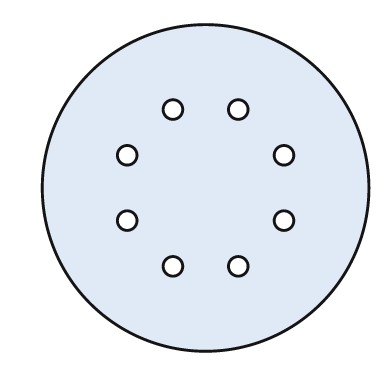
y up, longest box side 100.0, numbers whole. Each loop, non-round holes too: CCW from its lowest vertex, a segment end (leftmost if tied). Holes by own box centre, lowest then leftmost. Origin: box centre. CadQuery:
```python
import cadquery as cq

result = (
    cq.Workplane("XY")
    .moveTo(0.0, 0.0)
    .circle(50.0)
    .moveTo(-10.0, -24.0)
    .circle(3.0)
    .moveTo(10.0, -24.0)
    .circle(3.0)
    .moveTo(-24.0, -10.0)
    .circle(3.0)
    .moveTo(24.0, -10.0)
    .circle(3.0)
    .moveTo(-24.0, 10.0)
    .circle(3.0)
    .moveTo(24.0, 10.0)
    .circle(3.0)
    .moveTo(-10.0, 24.0)
    .circle(3.0)
    .moveTo(10.0, 24.0)
    .circle(3.0)
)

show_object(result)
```